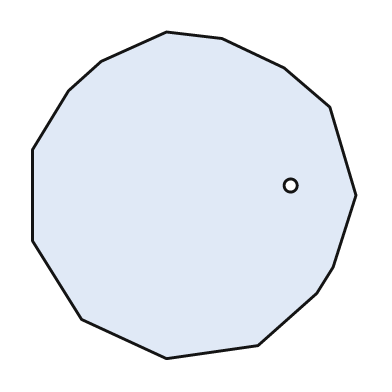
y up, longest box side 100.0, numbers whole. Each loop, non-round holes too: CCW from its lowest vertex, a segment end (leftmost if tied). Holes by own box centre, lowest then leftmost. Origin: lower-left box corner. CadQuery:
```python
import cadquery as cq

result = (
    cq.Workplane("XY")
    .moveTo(41.0, 0.0)
    .lineTo(69.0, 4.0)
    .lineTo(87.0, 20.0)
    .lineTo(92.0, 28.0)
    .lineTo(99.0, 50.0)
    .lineTo(91.0, 77.0)
    .lineTo(77.0, 89.0)
    .lineTo(58.0, 98.0)
    .lineTo(41.0, 100.0)
    .lineTo(21.0, 91.0)
    .lineTo(11.0, 82.0)
    .lineTo(0.0, 64.0)
    .lineTo(0.0, 36.0)
    .lineTo(15.0, 12.0)
    .close()
    .moveTo(79.0, 53.0)
    .circle(2.0)
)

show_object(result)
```